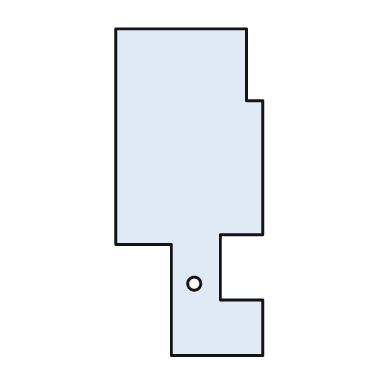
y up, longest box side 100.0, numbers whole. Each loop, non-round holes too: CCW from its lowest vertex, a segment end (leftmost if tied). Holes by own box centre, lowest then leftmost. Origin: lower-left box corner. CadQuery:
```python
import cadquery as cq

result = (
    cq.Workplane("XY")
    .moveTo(17.0, 0.0)
    .lineTo(45.0, 0.0)
    .lineTo(45.0, 17.0)
    .lineTo(32.0, 17.0)
    .lineTo(32.0, 37.0)
    .lineTo(45.0, 37.0)
    .lineTo(45.0, 78.0)
    .lineTo(40.0, 78.0)
    .lineTo(40.0, 100.0)
    .lineTo(0.0, 100.0)
    .lineTo(0.0, 34.0)
    .lineTo(17.0, 34.0)
    .close()
    .moveTo(24.0, 22.0)
    .circle(2.0)
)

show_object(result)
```